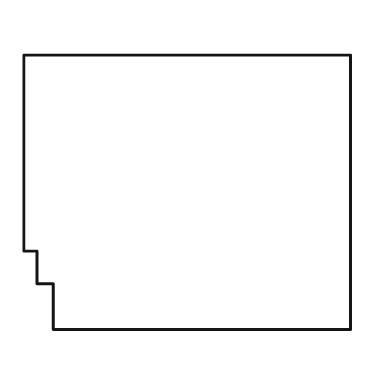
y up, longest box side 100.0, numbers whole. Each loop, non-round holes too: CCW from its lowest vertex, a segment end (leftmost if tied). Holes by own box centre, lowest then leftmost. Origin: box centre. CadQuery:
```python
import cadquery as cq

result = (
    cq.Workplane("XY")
    .moveTo(-41.0, -42.0)
    .lineTo(50.0, -42.0)
    .lineTo(50.0, 42.0)
    .lineTo(-50.0, 42.0)
    .lineTo(-50.0, -18.0)
    .lineTo(-46.0, -18.0)
    .lineTo(-46.0, -28.0)
    .lineTo(-41.0, -28.0)
    .close()
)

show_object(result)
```